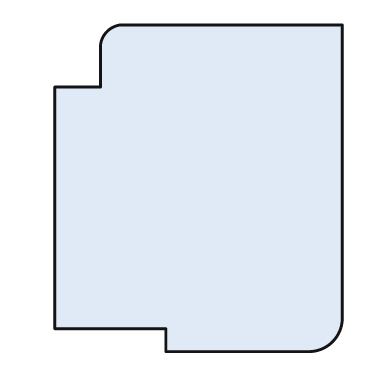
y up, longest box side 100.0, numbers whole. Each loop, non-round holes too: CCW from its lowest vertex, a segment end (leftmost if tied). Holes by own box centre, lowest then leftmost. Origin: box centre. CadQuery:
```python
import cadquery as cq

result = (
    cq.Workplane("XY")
    .moveTo(-10.0, -50.0)
    .lineTo(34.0, -50.0)
    .threePointArc((41.0, -47.0), (44.0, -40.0))
    .lineTo(44.0, 50.0)
    .lineTo(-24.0, 50.0)
    .threePointArc((-28.0, 48.0), (-30.0, 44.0))
    .lineTo(-30.0, 31.0)
    .lineTo(-44.0, 31.0)
    .lineTo(-44.0, -43.0)
    .lineTo(-10.0, -43.0)
    .close()
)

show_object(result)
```